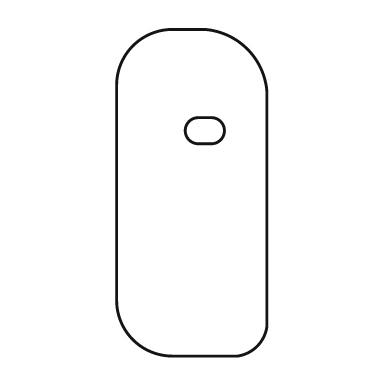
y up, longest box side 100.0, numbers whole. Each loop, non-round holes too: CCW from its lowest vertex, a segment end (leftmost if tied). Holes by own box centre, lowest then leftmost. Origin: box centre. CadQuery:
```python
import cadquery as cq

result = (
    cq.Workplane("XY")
    .moveTo(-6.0, -50.0)
    .lineTo(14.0, -50.0)
    .threePointArc((20.0, -47.0), (23.0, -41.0))
    .lineTo(23.0, 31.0)
    .threePointArc((17.0, 44.0), (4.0, 50.0))
    .lineTo(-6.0, 50.0)
    .threePointArc((-18.0, 45.0), (-23.0, 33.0))
    .lineTo(-23.0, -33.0)
    .threePointArc((-18.0, -45.0), (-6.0, -50.0))
    .close()
    .moveTo(2.0, 15.0)
    .lineTo(6.0, 15.0)
    .threePointArc((10.0, 19.0), (6.0, 23.0))
    .lineTo(2.0, 23.0)
    .threePointArc((-2.0, 19.0), (2.0, 15.0))
    .close()
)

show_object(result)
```